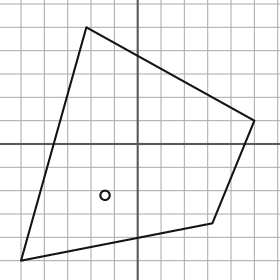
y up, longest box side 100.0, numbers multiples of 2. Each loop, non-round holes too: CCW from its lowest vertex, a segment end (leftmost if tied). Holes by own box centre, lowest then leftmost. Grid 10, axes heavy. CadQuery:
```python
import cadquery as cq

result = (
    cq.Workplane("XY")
    .moveTo(-50.0, -50.0)
    .lineTo(32.0, -34.0)
    .lineTo(50.0, 10.0)
    .lineTo(-22.0, 50.0)
    .close()
    .moveTo(-14.0, -22.0)
    .circle(2.0)
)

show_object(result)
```